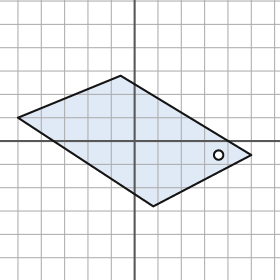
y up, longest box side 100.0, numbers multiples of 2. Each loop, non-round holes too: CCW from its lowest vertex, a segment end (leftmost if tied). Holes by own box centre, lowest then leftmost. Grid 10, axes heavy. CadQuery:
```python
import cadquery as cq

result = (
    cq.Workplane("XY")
    .moveTo(8.0, -28.0)
    .lineTo(50.0, -6.0)
    .lineTo(-6.0, 28.0)
    .lineTo(-50.0, 10.0)
    .close()
    .moveTo(36.0, -6.0)
    .circle(2.0)
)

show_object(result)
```